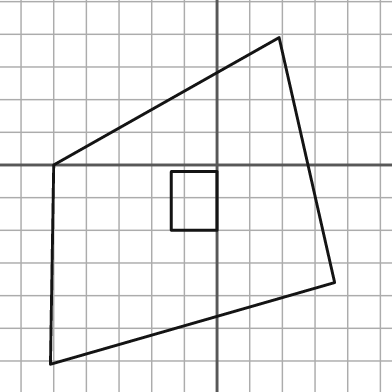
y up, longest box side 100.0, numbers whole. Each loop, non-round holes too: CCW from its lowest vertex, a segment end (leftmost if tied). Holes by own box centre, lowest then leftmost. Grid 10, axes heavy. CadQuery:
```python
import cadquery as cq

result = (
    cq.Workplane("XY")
    .moveTo(-51.0, -61.0)
    .lineTo(36.0, -36.0)
    .lineTo(19.0, 39.0)
    .lineTo(-50.0, 0.0)
    .close()
    .moveTo(-14.0, -20.0)
    .lineTo(0.0, -20.0)
    .lineTo(0.0, -2.0)
    .lineTo(-14.0, -2.0)
    .close()
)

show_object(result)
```